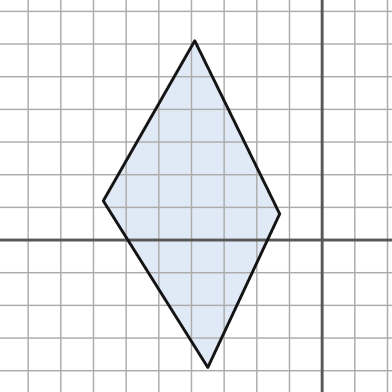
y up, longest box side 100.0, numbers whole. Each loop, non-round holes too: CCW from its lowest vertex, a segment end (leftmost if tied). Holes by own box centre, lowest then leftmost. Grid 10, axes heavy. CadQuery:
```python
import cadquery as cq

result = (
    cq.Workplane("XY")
    .moveTo(-35.0, -39.0)
    .lineTo(-13.0, 8.0)
    .lineTo(-39.0, 61.0)
    .lineTo(-67.0, 12.0)
    .close()
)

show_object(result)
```